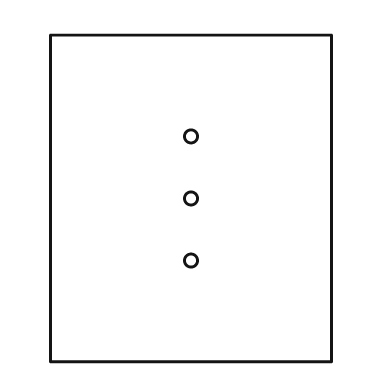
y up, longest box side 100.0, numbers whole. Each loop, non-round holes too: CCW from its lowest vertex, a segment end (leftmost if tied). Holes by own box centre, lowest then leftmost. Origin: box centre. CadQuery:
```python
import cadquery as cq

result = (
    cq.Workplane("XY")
    .moveTo(-43.0, -50.0)
    .lineTo(43.0, -50.0)
    .lineTo(43.0, 50.0)
    .lineTo(-43.0, 50.0)
    .close()
    .moveTo(0.0, -19.0)
    .circle(2.0)
    .moveTo(0.0, 0.0)
    .circle(2.0)
    .moveTo(0.0, 19.0)
    .circle(2.0)
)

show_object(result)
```